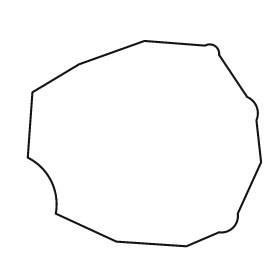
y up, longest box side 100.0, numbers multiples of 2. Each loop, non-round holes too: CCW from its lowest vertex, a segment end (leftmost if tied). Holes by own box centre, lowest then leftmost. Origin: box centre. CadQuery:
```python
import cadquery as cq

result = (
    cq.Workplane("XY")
    .moveTo(18.0, -44.0)
    .lineTo(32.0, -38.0)
    .threePointArc((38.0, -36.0), (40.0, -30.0))
    .lineTo(50.0, -8.0)
    .lineTo(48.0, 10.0)
    .threePointArc((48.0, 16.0), (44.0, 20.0))
    .lineTo(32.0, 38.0)
    .threePointArc((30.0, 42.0), (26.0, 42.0))
    .lineTo(0.0, 44.0)
    .lineTo(-28.0, 34.0)
    .lineTo(-48.0, 22.0)
    .lineTo(-50.0, -6.0)
    .threePointArc((-40.0, -16.0), (-38.0, -30.0))
    .lineTo(-12.0, -42.0)
    .close()
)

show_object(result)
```